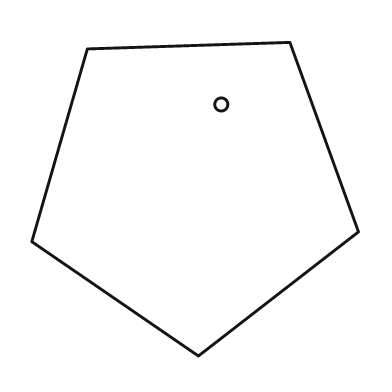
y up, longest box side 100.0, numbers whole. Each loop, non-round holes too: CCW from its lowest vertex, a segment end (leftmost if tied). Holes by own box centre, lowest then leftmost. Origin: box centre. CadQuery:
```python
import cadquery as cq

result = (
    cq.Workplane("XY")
    .moveTo(1.0, -48.0)
    .lineTo(50.0, -10.0)
    .lineTo(29.0, 48.0)
    .lineTo(-33.0, 46.0)
    .lineTo(-50.0, -13.0)
    .close()
    .moveTo(8.0, 29.0)
    .circle(2.0)
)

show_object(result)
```